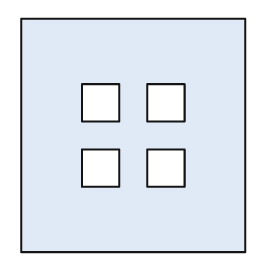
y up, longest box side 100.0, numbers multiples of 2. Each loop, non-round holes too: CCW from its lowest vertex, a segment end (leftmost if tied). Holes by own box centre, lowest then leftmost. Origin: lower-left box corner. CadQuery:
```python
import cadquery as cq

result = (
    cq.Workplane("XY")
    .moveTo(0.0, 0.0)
    .lineTo(96.0, 0.0)
    .lineTo(96.0, 100.0)
    .lineTo(0.0, 100.0)
    .close()
    .moveTo(26.0, 28.0)
    .lineTo(42.0, 28.0)
    .lineTo(42.0, 44.0)
    .lineTo(26.0, 44.0)
    .close()
    .moveTo(54.0, 28.0)
    .lineTo(70.0, 28.0)
    .lineTo(70.0, 44.0)
    .lineTo(54.0, 44.0)
    .close()
    .moveTo(26.0, 56.0)
    .lineTo(42.0, 56.0)
    .lineTo(42.0, 72.0)
    .lineTo(26.0, 72.0)
    .close()
    .moveTo(54.0, 56.0)
    .lineTo(70.0, 56.0)
    .lineTo(70.0, 72.0)
    .lineTo(54.0, 72.0)
    .close()
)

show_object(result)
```